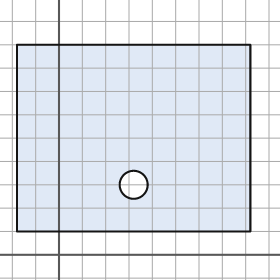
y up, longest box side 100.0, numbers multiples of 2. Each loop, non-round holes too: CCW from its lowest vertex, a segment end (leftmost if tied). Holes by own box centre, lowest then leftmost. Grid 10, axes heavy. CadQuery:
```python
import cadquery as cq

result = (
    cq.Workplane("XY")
    .moveTo(-18.0, 10.0)
    .lineTo(82.0, 10.0)
    .lineTo(82.0, 90.0)
    .lineTo(-18.0, 90.0)
    .close()
    .moveTo(32.0, 30.0)
    .circle(6.0)
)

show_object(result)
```